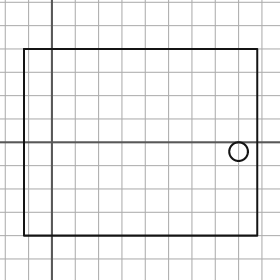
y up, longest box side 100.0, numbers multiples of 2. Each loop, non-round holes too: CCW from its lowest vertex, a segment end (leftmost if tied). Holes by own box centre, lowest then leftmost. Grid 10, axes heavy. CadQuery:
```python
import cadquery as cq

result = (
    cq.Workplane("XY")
    .moveTo(-12.0, -40.0)
    .lineTo(88.0, -40.0)
    .lineTo(88.0, 40.0)
    .lineTo(-12.0, 40.0)
    .close()
    .moveTo(80.0, -4.0)
    .circle(4.0)
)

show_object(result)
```